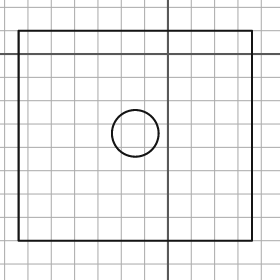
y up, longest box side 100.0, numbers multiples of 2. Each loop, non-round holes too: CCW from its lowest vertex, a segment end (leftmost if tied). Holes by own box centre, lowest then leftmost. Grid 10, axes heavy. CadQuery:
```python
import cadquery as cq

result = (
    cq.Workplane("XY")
    .moveTo(-64.0, -80.0)
    .lineTo(36.0, -80.0)
    .lineTo(36.0, 10.0)
    .lineTo(-64.0, 10.0)
    .close()
    .moveTo(-14.0, -34.0)
    .circle(10.0)
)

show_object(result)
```